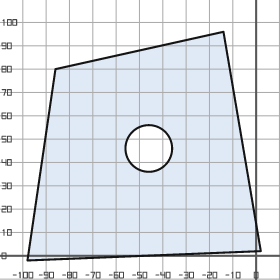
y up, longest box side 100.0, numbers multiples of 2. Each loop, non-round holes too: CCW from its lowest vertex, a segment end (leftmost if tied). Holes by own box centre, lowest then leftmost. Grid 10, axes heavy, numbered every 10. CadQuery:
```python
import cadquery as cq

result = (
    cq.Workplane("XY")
    .moveTo(-98.0, -2.0)
    .lineTo(2.0, 2.0)
    .lineTo(-14.0, 96.0)
    .lineTo(-86.0, 80.0)
    .close()
    .moveTo(-46.0, 46.0)
    .circle(10.0)
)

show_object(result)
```